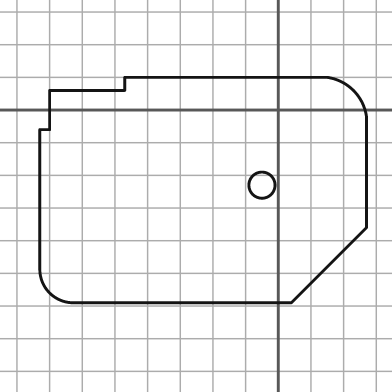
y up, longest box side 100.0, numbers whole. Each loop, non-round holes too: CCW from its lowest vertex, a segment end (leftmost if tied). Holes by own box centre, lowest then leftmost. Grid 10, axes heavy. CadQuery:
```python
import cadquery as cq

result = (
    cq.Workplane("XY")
    .moveTo(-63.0, -59.0)
    .lineTo(4.0, -59.0)
    .lineTo(27.0, -36.0)
    .lineTo(27.0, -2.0)
    .threePointArc((23.0, 6.0), (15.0, 10.0))
    .lineTo(-47.0, 10.0)
    .lineTo(-47.0, 6.0)
    .lineTo(-70.0, 6.0)
    .lineTo(-70.0, -6.0)
    .lineTo(-73.0, -6.0)
    .lineTo(-73.0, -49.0)
    .threePointArc((-70.0, -56.0), (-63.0, -59.0))
    .close()
    .moveTo(-5.0, -23.0)
    .circle(4.0)
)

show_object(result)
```